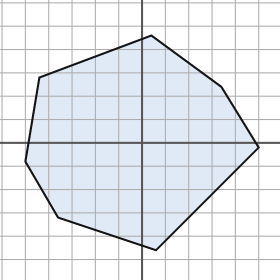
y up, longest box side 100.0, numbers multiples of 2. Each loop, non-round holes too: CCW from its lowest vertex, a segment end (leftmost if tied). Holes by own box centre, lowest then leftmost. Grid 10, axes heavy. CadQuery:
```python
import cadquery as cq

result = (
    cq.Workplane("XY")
    .moveTo(6.0, -46.0)
    .lineTo(50.0, -2.0)
    .lineTo(34.0, 24.0)
    .lineTo(4.0, 46.0)
    .lineTo(-44.0, 28.0)
    .lineTo(-50.0, -8.0)
    .lineTo(-36.0, -32.0)
    .close()
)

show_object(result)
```